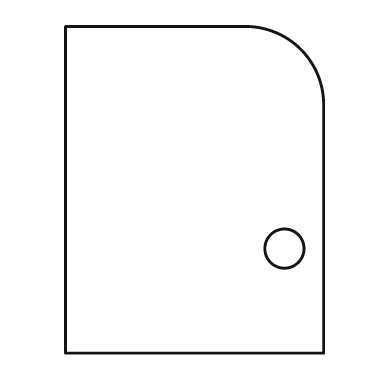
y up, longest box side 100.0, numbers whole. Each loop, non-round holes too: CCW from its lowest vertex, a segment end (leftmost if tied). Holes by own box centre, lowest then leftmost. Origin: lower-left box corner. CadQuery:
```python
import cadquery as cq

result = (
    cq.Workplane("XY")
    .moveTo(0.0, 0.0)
    .lineTo(79.0, 0.0)
    .lineTo(79.0, 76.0)
    .threePointArc((72.0, 93.0), (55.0, 100.0))
    .lineTo(0.0, 100.0)
    .close()
    .moveTo(67.0, 32.0)
    .circle(6.0)
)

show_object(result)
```